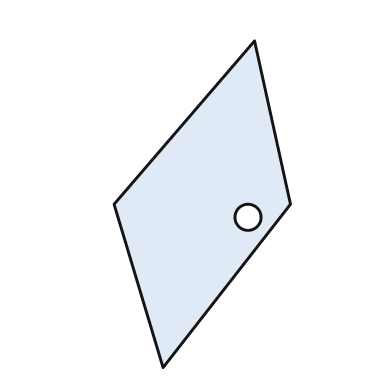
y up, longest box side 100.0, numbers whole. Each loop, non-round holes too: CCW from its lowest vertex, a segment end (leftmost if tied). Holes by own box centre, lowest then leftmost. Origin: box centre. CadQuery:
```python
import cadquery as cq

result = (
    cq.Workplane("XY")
    .moveTo(-12.0, -50.0)
    .lineTo(27.0, 0.0)
    .lineTo(16.0, 50.0)
    .lineTo(-27.0, 0.0)
    .close()
    .moveTo(14.0, -4.0)
    .circle(4.0)
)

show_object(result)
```